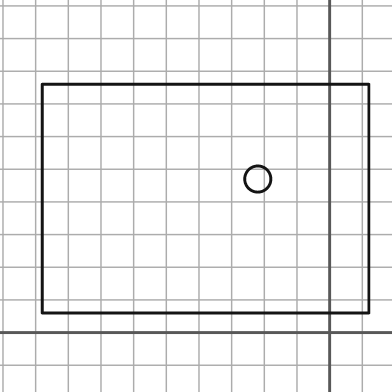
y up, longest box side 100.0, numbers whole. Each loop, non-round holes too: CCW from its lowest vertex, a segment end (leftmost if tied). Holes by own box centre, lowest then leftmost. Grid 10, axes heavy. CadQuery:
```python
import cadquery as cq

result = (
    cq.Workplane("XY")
    .moveTo(-88.0, 6.0)
    .lineTo(12.0, 6.0)
    .lineTo(12.0, 76.0)
    .lineTo(-88.0, 76.0)
    .close()
    .moveTo(-22.0, 47.0)
    .circle(4.0)
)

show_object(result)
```